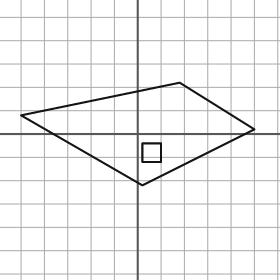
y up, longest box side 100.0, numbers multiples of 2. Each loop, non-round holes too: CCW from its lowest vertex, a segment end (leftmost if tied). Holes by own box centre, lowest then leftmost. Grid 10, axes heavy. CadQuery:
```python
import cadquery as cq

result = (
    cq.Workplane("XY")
    .moveTo(2.0, -22.0)
    .lineTo(50.0, 2.0)
    .lineTo(18.0, 22.0)
    .lineTo(-50.0, 8.0)
    .close()
    .moveTo(2.0, -12.0)
    .lineTo(10.0, -12.0)
    .lineTo(10.0, -4.0)
    .lineTo(2.0, -4.0)
    .close()
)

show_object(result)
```